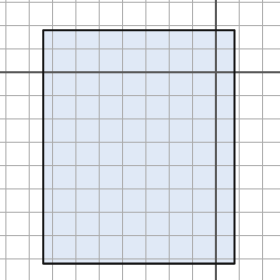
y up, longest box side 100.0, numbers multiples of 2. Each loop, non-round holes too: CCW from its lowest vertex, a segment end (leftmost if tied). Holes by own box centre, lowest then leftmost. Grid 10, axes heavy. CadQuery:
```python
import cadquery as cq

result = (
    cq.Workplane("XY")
    .moveTo(-74.0, -82.0)
    .lineTo(8.0, -82.0)
    .lineTo(8.0, 18.0)
    .lineTo(-74.0, 18.0)
    .close()
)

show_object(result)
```